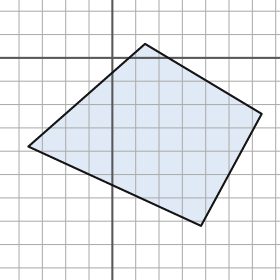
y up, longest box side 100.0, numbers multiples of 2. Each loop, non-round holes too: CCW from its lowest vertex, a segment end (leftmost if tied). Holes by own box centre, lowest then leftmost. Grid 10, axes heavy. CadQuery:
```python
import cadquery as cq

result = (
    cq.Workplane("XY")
    .moveTo(38.0, -72.0)
    .lineTo(64.0, -24.0)
    .lineTo(14.0, 6.0)
    .lineTo(-36.0, -38.0)
    .close()
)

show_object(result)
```